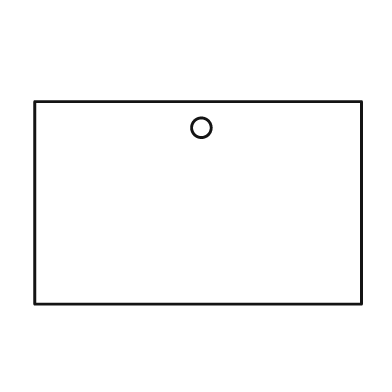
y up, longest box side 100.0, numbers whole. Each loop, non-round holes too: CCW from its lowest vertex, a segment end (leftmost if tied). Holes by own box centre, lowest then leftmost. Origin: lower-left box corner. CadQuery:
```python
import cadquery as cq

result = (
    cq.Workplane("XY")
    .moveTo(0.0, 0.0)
    .lineTo(100.0, 0.0)
    .lineTo(100.0, 62.0)
    .lineTo(0.0, 62.0)
    .close()
    .moveTo(51.0, 54.0)
    .circle(3.0)
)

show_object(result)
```